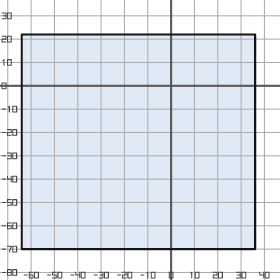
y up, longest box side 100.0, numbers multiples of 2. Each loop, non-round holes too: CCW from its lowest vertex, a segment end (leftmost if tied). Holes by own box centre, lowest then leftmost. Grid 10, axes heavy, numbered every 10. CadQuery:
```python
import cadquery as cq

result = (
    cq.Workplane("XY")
    .moveTo(-64.0, -70.0)
    .lineTo(36.0, -70.0)
    .lineTo(36.0, 22.0)
    .lineTo(-64.0, 22.0)
    .close()
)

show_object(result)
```